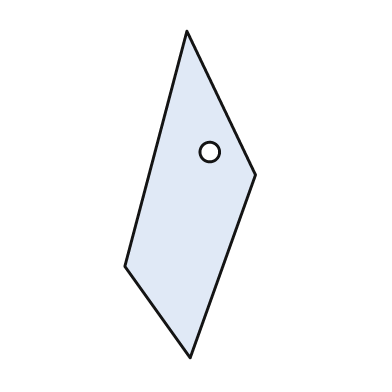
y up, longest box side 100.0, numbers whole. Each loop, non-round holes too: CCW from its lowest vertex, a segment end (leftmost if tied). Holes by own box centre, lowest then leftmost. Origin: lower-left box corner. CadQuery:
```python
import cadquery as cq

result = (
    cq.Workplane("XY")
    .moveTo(20.0, 0.0)
    .lineTo(40.0, 56.0)
    .lineTo(19.0, 100.0)
    .lineTo(0.0, 28.0)
    .close()
    .moveTo(26.0, 63.0)
    .circle(3.0)
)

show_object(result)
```